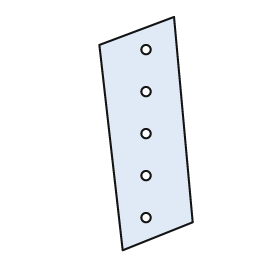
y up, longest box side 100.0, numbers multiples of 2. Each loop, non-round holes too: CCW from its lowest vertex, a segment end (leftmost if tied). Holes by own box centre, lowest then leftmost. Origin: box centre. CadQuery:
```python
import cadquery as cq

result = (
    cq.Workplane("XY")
    .moveTo(-10.0, -50.0)
    .lineTo(20.0, -38.0)
    .lineTo(12.0, 50.0)
    .lineTo(-20.0, 38.0)
    .close()
    .moveTo(0.0, -36.0)
    .circle(2.0)
    .moveTo(0.0, -18.0)
    .circle(2.0)
    .moveTo(0.0, 0.0)
    .circle(2.0)
    .moveTo(0.0, 18.0)
    .circle(2.0)
    .moveTo(0.0, 36.0)
    .circle(2.0)
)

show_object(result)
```